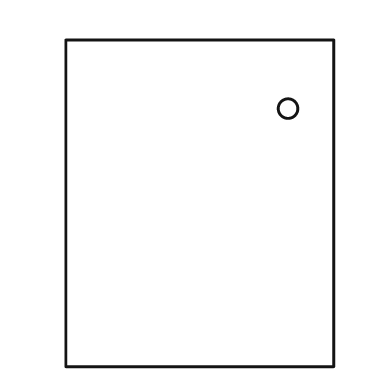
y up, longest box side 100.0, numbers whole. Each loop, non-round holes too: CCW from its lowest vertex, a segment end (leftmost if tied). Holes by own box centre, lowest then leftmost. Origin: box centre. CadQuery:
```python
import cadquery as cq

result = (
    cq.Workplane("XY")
    .moveTo(-41.0, -50.0)
    .lineTo(41.0, -50.0)
    .lineTo(41.0, 50.0)
    .lineTo(-41.0, 50.0)
    .close()
    .moveTo(27.0, 29.0)
    .circle(3.0)
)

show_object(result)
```